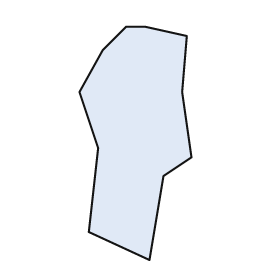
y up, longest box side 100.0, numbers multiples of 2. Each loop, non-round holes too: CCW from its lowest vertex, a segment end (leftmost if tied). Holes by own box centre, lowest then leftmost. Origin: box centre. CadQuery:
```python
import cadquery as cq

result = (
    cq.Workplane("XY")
    .moveTo(6.0, -50.0)
    .lineTo(12.0, -14.0)
    .lineTo(24.0, -6.0)
    .lineTo(20.0, 22.0)
    .lineTo(22.0, 46.0)
    .lineTo(4.0, 50.0)
    .lineTo(-4.0, 50.0)
    .lineTo(-14.0, 40.0)
    .lineTo(-24.0, 22.0)
    .lineTo(-16.0, -2.0)
    .lineTo(-20.0, -38.0)
    .close()
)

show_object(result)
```